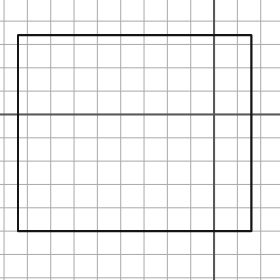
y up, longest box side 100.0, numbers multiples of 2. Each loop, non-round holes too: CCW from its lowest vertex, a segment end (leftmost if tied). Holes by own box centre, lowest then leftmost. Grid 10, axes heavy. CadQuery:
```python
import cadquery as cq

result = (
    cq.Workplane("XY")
    .moveTo(-84.0, -50.0)
    .lineTo(16.0, -50.0)
    .lineTo(16.0, 34.0)
    .lineTo(-84.0, 34.0)
    .close()
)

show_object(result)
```